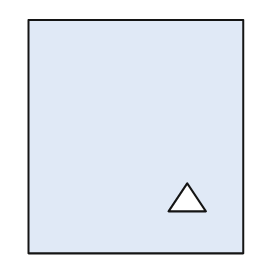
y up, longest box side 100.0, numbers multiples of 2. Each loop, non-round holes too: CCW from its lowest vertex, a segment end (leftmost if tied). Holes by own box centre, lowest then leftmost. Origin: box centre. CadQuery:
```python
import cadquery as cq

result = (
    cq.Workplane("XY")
    .moveTo(-46.0, -50.0)
    .lineTo(46.0, -50.0)
    .lineTo(46.0, 50.0)
    .lineTo(-46.0, 50.0)
    .close()
    .moveTo(14.0, -32.0)
    .lineTo(30.0, -32.0)
    .lineTo(22.0, -20.0)
    .close()
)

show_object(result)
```